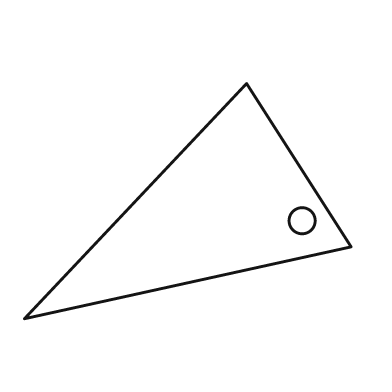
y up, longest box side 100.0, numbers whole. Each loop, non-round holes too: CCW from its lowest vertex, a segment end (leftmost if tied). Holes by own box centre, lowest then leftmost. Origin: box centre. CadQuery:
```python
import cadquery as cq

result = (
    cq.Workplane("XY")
    .moveTo(-50.0, -36.0)
    .lineTo(50.0, -14.0)
    .lineTo(18.0, 36.0)
    .close()
    .moveTo(35.0, -6.0)
    .circle(4.0)
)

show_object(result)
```